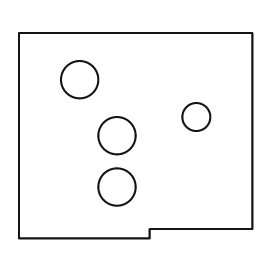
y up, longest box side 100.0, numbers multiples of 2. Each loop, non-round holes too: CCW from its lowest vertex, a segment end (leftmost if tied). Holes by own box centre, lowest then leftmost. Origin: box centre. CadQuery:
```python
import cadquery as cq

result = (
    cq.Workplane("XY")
    .moveTo(-50.0, -44.0)
    .lineTo(6.0, -44.0)
    .lineTo(6.0, -40.0)
    .lineTo(50.0, -40.0)
    .lineTo(50.0, 44.0)
    .lineTo(-50.0, 44.0)
    .close()
    .moveTo(-8.0, -22.0)
    .circle(8.0)
    .moveTo(-8.0, 0.0)
    .circle(8.0)
    .moveTo(26.0, 8.0)
    .circle(6.0)
    .moveTo(-24.0, 24.0)
    .circle(8.0)
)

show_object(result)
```